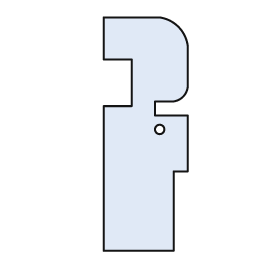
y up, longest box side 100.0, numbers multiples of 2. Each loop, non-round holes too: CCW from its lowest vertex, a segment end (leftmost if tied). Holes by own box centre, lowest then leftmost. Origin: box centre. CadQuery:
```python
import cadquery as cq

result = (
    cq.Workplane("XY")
    .moveTo(-18.0, -50.0)
    .lineTo(12.0, -50.0)
    .lineTo(12.0, -16.0)
    .lineTo(18.0, -16.0)
    .lineTo(18.0, 8.0)
    .lineTo(4.0, 8.0)
    .lineTo(4.0, 14.0)
    .lineTo(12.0, 14.0)
    .threePointArc((16.0, 16.0), (18.0, 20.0))
    .lineTo(18.0, 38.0)
    .threePointArc((14.0, 46.0), (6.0, 50.0))
    .lineTo(-18.0, 50.0)
    .lineTo(-18.0, 32.0)
    .lineTo(-6.0, 32.0)
    .lineTo(-6.0, 12.0)
    .lineTo(-18.0, 12.0)
    .close()
    .moveTo(6.0, 2.0)
    .circle(2.0)
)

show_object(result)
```